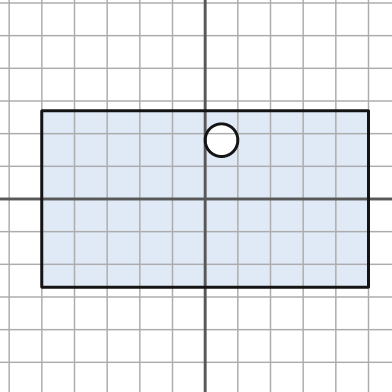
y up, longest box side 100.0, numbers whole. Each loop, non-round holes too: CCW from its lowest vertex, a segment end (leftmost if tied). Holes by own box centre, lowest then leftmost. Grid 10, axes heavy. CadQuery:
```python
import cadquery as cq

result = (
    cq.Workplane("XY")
    .moveTo(-50.0, -27.0)
    .lineTo(50.0, -27.0)
    .lineTo(50.0, 27.0)
    .lineTo(-50.0, 27.0)
    .close()
    .moveTo(5.0, 18.0)
    .circle(5.0)
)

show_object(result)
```